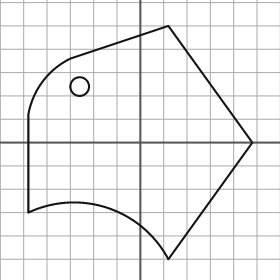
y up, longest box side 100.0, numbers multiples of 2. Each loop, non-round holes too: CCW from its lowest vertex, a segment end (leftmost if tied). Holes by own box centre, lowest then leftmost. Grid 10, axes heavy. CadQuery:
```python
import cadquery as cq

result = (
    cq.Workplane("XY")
    .moveTo(12.0, -50.0)
    .lineTo(48.0, 0.0)
    .lineTo(12.0, 50.0)
    .lineTo(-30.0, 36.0)
    .threePointArc((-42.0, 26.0), (-48.0, 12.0))
    .lineTo(-48.0, -30.0)
    .threePointArc((-14.0, -28.0), (12.0, -50.0))
    .close()
    .moveTo(-26.0, 24.0)
    .circle(4.0)
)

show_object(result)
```